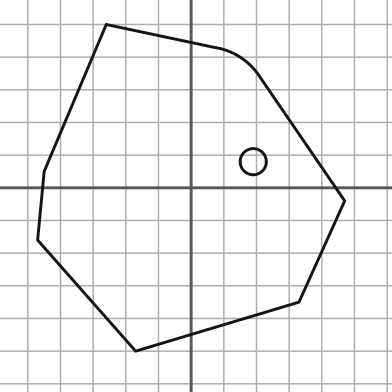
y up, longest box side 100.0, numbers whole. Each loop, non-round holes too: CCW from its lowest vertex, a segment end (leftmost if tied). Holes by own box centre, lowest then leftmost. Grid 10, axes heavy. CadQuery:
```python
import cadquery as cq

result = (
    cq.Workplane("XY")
    .moveTo(-17.0, -50.0)
    .lineTo(33.0, -35.0)
    .lineTo(47.0, -4.0)
    .lineTo(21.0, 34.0)
    .threePointArc((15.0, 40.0), (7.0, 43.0))
    .lineTo(-26.0, 50.0)
    .lineTo(-45.0, 5.0)
    .lineTo(-47.0, -16.0)
    .close()
    .moveTo(19.0, 8.0)
    .circle(4.0)
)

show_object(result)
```